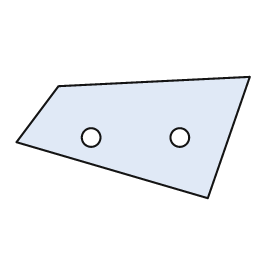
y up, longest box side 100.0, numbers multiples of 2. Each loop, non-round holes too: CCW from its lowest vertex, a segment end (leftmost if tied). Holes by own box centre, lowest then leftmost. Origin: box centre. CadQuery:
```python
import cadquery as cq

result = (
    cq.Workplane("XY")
    .moveTo(32.0, -26.0)
    .lineTo(50.0, 26.0)
    .lineTo(-32.0, 22.0)
    .lineTo(-50.0, -2.0)
    .close()
    .moveTo(-18.0, 0.0)
    .circle(4.0)
    .moveTo(20.0, 0.0)
    .circle(4.0)
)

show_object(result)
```